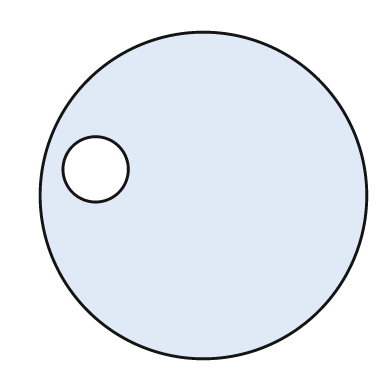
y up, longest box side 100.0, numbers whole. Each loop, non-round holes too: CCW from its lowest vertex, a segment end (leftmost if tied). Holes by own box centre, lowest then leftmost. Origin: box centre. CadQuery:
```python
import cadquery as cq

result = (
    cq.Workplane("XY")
    .moveTo(0.0, 0.0)
    .circle(50.0)
    .moveTo(-33.0, 8.0)
    .circle(10.0)
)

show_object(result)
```